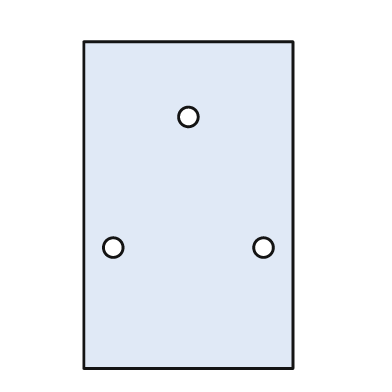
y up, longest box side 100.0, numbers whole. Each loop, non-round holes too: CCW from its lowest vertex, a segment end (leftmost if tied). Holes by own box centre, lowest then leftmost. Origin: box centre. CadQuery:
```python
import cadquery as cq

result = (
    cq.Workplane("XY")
    .moveTo(-32.0, -50.0)
    .lineTo(32.0, -50.0)
    .lineTo(32.0, 50.0)
    .lineTo(-32.0, 50.0)
    .close()
    .moveTo(-23.0, -13.0)
    .circle(3.0)
    .moveTo(23.0, -13.0)
    .circle(3.0)
    .moveTo(0.0, 27.0)
    .circle(3.0)
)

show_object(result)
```